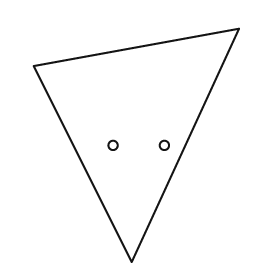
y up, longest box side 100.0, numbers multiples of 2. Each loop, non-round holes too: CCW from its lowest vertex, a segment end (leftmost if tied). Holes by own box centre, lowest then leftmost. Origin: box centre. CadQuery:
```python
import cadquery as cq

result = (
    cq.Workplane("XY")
    .moveTo(-2.0, -50.0)
    .lineTo(44.0, 50.0)
    .lineTo(-44.0, 34.0)
    .close()
    .moveTo(-10.0, 0.0)
    .circle(2.0)
    .moveTo(12.0, 0.0)
    .circle(2.0)
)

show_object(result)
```